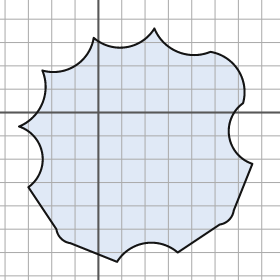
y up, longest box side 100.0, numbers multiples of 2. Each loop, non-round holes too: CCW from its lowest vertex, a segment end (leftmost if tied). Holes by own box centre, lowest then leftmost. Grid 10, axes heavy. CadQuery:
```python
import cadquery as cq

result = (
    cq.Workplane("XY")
    .moveTo(8.0, -64.0)
    .threePointArc((20.0, -56.0), (34.0, -60.0))
    .lineTo(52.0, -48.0)
    .threePointArc((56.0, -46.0), (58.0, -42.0))
    .lineTo(66.0, -22.0)
    .threePointArc((56.0, -10.0), (62.0, 4.0))
    .threePointArc((60.0, 18.0), (48.0, 26.0))
    .threePointArc((34.0, 26.0), (24.0, 36.0))
    .threePointArc((12.0, 28.0), (-2.0, 32.0))
    .threePointArc((-10.0, 20.0), (-24.0, 18.0))
    .threePointArc((-24.0, 4.0), (-34.0, -6.0))
    .threePointArc((-24.0, -18.0), (-30.0, -32.0))
    .lineTo(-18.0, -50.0)
    .threePointArc((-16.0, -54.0), (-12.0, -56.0))
    .close()
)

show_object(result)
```